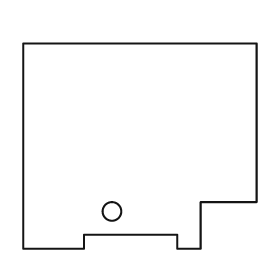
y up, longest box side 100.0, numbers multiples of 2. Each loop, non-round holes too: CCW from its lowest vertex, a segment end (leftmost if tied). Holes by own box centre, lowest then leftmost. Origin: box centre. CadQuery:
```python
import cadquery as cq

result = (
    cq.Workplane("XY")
    .moveTo(-50.0, -44.0)
    .lineTo(-24.0, -44.0)
    .lineTo(-24.0, -38.0)
    .lineTo(16.0, -38.0)
    .lineTo(16.0, -44.0)
    .lineTo(26.0, -44.0)
    .lineTo(26.0, -24.0)
    .lineTo(50.0, -24.0)
    .lineTo(50.0, 44.0)
    .lineTo(-50.0, 44.0)
    .close()
    .moveTo(-12.0, -28.0)
    .circle(4.0)
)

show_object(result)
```